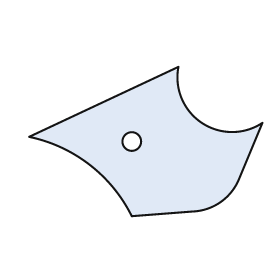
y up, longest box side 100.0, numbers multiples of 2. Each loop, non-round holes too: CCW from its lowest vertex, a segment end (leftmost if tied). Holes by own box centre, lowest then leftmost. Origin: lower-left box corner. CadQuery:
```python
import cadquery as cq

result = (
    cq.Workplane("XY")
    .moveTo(44.0, 0.0)
    .lineTo(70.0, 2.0)
    .threePointArc((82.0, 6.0), (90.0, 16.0))
    .lineTo(100.0, 40.0)
    .threePointArc((74.0, 40.0), (64.0, 64.0))
    .lineTo(0.0, 34.0)
    .threePointArc((26.0, 22.0), (44.0, 0.0))
    .close()
    .moveTo(44.0, 32.0)
    .circle(4.0)
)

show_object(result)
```